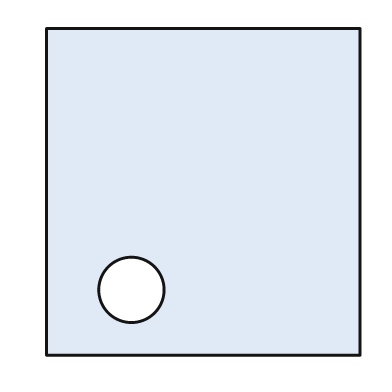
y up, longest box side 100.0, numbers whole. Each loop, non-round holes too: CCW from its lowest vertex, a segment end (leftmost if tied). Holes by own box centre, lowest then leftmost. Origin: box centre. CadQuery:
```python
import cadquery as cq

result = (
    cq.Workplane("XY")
    .moveTo(-48.0, -50.0)
    .lineTo(48.0, -50.0)
    .lineTo(48.0, 50.0)
    .lineTo(-48.0, 50.0)
    .close()
    .moveTo(-22.0, -30.0)
    .circle(10.0)
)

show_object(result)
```